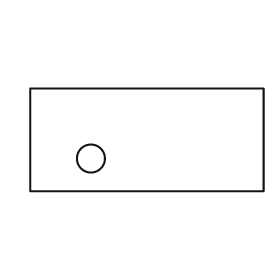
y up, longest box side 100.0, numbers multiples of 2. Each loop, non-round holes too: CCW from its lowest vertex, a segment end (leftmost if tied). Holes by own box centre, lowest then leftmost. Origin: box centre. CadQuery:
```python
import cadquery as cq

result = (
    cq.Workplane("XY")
    .moveTo(-50.0, -22.0)
    .lineTo(50.0, -22.0)
    .lineTo(50.0, 22.0)
    .lineTo(-50.0, 22.0)
    .close()
    .moveTo(-24.0, -8.0)
    .circle(6.0)
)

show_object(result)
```